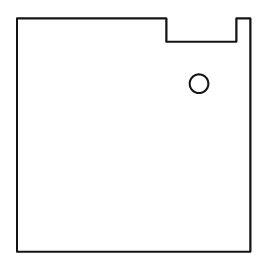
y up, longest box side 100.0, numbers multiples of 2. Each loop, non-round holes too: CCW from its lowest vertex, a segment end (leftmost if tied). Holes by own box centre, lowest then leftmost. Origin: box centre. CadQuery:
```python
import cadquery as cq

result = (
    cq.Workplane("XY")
    .moveTo(-50.0, -50.0)
    .lineTo(50.0, -50.0)
    .lineTo(50.0, 50.0)
    .lineTo(44.0, 50.0)
    .lineTo(44.0, 40.0)
    .lineTo(14.0, 40.0)
    .lineTo(14.0, 50.0)
    .lineTo(-50.0, 50.0)
    .close()
    .moveTo(28.0, 22.0)
    .circle(4.0)
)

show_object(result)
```